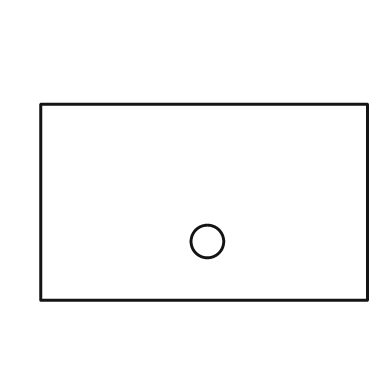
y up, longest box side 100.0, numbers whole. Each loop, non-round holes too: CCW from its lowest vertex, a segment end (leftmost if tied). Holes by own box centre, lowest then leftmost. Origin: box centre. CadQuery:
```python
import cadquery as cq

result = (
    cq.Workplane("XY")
    .moveTo(-50.0, -30.0)
    .lineTo(50.0, -30.0)
    .lineTo(50.0, 30.0)
    .lineTo(-50.0, 30.0)
    .close()
    .moveTo(1.0, -12.0)
    .circle(5.0)
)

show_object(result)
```